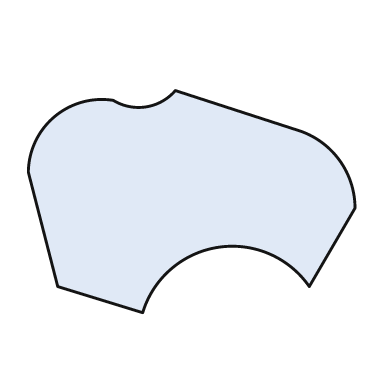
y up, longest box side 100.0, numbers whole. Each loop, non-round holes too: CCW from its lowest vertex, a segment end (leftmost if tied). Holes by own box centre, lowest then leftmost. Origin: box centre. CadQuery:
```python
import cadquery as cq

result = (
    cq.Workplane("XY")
    .moveTo(-15.0, -34.0)
    .threePointArc((8.0, -14.0), (36.0, -26.0))
    .lineTo(50.0, -2.0)
    .threePointArc((45.0, 13.0), (32.0, 22.0))
    .lineTo(-5.0, 34.0)
    .threePointArc((-14.0, 29.0), (-24.0, 31.0))
    .threePointArc((-42.0, 26.0), (-50.0, 9.0))
    .lineTo(-41.0, -26.0)
    .close()
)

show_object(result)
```